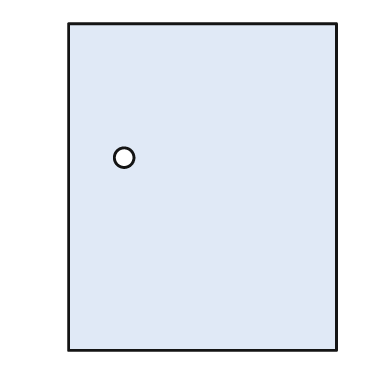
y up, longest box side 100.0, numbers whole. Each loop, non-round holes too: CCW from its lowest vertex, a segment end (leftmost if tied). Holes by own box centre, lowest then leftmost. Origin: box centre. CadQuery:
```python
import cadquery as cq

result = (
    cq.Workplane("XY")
    .moveTo(-41.0, -50.0)
    .lineTo(41.0, -50.0)
    .lineTo(41.0, 50.0)
    .lineTo(-41.0, 50.0)
    .close()
    .moveTo(-24.0, 9.0)
    .circle(3.0)
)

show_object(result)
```